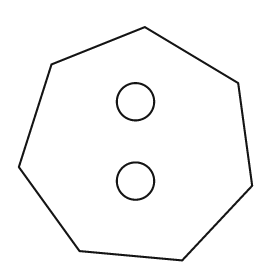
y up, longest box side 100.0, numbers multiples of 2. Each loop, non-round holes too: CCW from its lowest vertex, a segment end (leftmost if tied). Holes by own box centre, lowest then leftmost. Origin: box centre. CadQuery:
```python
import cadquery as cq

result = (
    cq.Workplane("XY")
    .moveTo(20.0, -50.0)
    .lineTo(50.0, -18.0)
    .lineTo(44.0, 26.0)
    .lineTo(4.0, 50.0)
    .lineTo(-36.0, 34.0)
    .lineTo(-50.0, -10.0)
    .lineTo(-24.0, -46.0)
    .close()
    .moveTo(0.0, -16.0)
    .circle(8.0)
    .moveTo(0.0, 18.0)
    .circle(8.0)
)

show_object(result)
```